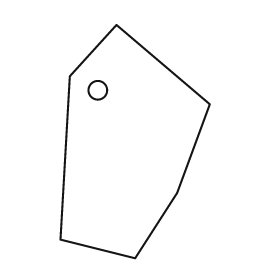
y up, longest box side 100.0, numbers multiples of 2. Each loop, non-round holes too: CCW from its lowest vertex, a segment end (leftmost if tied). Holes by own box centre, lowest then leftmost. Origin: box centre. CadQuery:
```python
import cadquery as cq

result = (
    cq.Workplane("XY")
    .moveTo(0.0, -50.0)
    .lineTo(18.0, -22.0)
    .lineTo(32.0, 16.0)
    .lineTo(-8.0, 50.0)
    .lineTo(-28.0, 28.0)
    .lineTo(-32.0, -42.0)
    .close()
    .moveTo(-16.0, 22.0)
    .circle(4.0)
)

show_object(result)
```